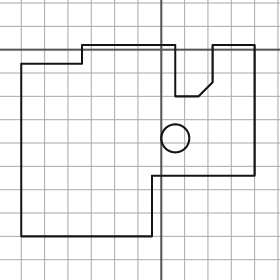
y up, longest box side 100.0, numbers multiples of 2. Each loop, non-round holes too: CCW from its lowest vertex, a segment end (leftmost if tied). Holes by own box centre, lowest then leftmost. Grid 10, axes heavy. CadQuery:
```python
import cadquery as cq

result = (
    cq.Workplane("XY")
    .moveTo(-60.0, -80.0)
    .lineTo(-4.0, -80.0)
    .lineTo(-4.0, -54.0)
    .lineTo(40.0, -54.0)
    .lineTo(40.0, 2.0)
    .lineTo(22.0, 2.0)
    .lineTo(22.0, -14.0)
    .lineTo(16.0, -20.0)
    .lineTo(6.0, -20.0)
    .lineTo(6.0, 2.0)
    .lineTo(-34.0, 2.0)
    .lineTo(-34.0, -6.0)
    .lineTo(-60.0, -6.0)
    .close()
    .moveTo(6.0, -38.0)
    .circle(6.0)
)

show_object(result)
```